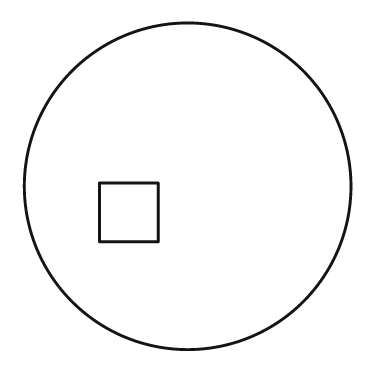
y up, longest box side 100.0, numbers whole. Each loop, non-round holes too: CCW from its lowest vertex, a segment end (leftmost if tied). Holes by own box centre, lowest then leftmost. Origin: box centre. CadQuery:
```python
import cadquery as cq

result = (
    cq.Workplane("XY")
    .moveTo(0.0, 0.0)
    .circle(50.0)
    .moveTo(-27.0, -17.0)
    .lineTo(-9.0, -17.0)
    .lineTo(-9.0, 1.0)
    .lineTo(-27.0, 1.0)
    .close()
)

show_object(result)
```